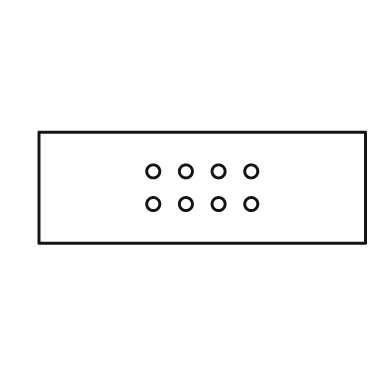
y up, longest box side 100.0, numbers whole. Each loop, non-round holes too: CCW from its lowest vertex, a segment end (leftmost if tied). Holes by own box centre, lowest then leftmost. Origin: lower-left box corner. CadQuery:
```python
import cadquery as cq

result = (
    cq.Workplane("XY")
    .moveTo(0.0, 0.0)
    .lineTo(100.0, 0.0)
    .lineTo(100.0, 34.0)
    .lineTo(0.0, 34.0)
    .close()
    .moveTo(35.0, 12.0)
    .circle(2.0)
    .moveTo(45.0, 12.0)
    .circle(2.0)
    .moveTo(55.0, 12.0)
    .circle(2.0)
    .moveTo(65.0, 12.0)
    .circle(2.0)
    .moveTo(35.0, 22.0)
    .circle(2.0)
    .moveTo(45.0, 22.0)
    .circle(2.0)
    .moveTo(55.0, 22.0)
    .circle(2.0)
    .moveTo(65.0, 22.0)
    .circle(2.0)
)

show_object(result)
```